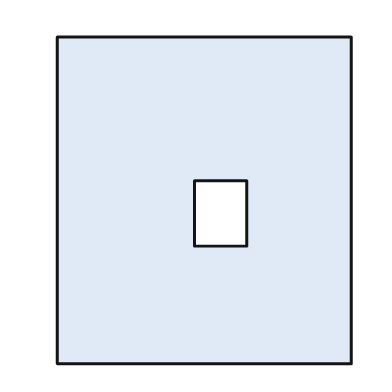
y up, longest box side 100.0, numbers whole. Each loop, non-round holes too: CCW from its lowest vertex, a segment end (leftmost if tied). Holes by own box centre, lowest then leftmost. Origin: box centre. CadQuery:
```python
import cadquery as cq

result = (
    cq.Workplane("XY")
    .moveTo(-45.0, -50.0)
    .lineTo(45.0, -50.0)
    .lineTo(45.0, 50.0)
    .lineTo(-45.0, 50.0)
    .close()
    .moveTo(-3.0, -14.0)
    .lineTo(13.0, -14.0)
    .lineTo(13.0, 6.0)
    .lineTo(-3.0, 6.0)
    .close()
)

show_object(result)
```